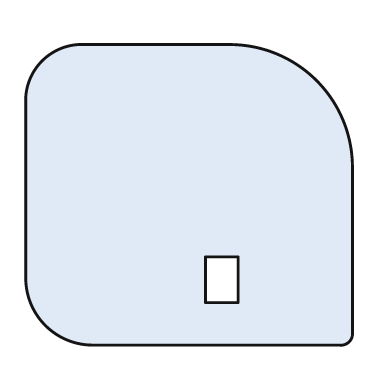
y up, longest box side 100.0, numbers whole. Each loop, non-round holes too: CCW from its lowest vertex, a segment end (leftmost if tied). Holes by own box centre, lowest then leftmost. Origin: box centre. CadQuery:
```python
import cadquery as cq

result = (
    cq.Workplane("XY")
    .moveTo(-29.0, -46.0)
    .lineTo(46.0, -46.0)
    .threePointArc((49.0, -45.0), (50.0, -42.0))
    .lineTo(50.0, 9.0)
    .threePointArc((39.0, 35.0), (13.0, 46.0))
    .lineTo(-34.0, 46.0)
    .threePointArc((-45.0, 41.0), (-50.0, 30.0))
    .lineTo(-50.0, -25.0)
    .threePointArc((-44.0, -40.0), (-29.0, -46.0))
    .close()
    .moveTo(5.0, -33.0)
    .lineTo(15.0, -33.0)
    .lineTo(15.0, -19.0)
    .lineTo(5.0, -19.0)
    .close()
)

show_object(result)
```